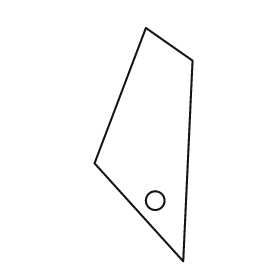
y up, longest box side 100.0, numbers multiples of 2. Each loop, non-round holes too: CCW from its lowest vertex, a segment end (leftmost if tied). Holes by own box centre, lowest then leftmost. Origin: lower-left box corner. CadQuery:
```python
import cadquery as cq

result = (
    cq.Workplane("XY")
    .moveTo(38.0, 0.0)
    .lineTo(42.0, 86.0)
    .lineTo(22.0, 100.0)
    .lineTo(0.0, 42.0)
    .close()
    .moveTo(26.0, 26.0)
    .circle(4.0)
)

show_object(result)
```